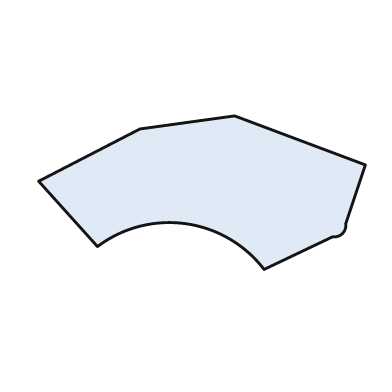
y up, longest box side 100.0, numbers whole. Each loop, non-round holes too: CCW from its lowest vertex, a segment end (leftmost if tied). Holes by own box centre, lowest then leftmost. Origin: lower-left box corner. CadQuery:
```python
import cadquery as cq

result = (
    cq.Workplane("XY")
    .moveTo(69.0, 0.0)
    .lineTo(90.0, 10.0)
    .threePointArc((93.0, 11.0), (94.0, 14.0))
    .lineTo(100.0, 32.0)
    .lineTo(60.0, 47.0)
    .lineTo(31.0, 43.0)
    .lineTo(0.0, 27.0)
    .lineTo(18.0, 7.0)
    .threePointArc((45.0, 14.0), (69.0, 0.0))
    .close()
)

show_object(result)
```